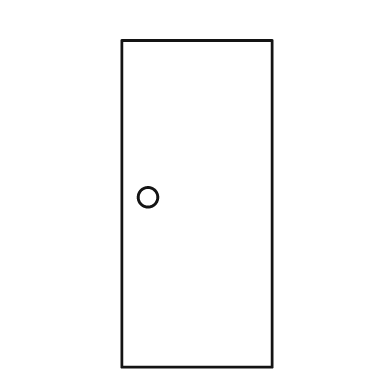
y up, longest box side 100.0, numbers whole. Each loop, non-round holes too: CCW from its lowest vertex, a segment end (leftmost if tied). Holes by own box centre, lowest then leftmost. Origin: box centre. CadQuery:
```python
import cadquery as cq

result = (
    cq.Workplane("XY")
    .moveTo(-23.0, -50.0)
    .lineTo(23.0, -50.0)
    .lineTo(23.0, 50.0)
    .lineTo(-23.0, 50.0)
    .close()
    .moveTo(-15.0, 2.0)
    .circle(3.0)
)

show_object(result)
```